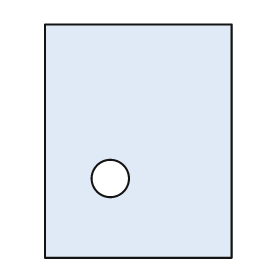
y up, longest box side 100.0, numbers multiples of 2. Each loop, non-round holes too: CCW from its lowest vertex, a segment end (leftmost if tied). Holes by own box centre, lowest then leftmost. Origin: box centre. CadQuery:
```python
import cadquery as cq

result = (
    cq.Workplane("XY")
    .moveTo(-40.0, -50.0)
    .lineTo(40.0, -50.0)
    .lineTo(40.0, 50.0)
    .lineTo(-40.0, 50.0)
    .close()
    .moveTo(-12.0, -16.0)
    .circle(8.0)
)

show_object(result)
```